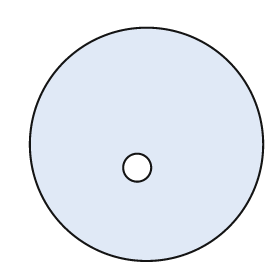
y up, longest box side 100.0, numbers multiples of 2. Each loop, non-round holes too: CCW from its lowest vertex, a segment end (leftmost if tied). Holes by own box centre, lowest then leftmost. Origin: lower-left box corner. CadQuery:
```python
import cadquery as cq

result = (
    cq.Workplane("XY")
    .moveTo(50.0, 50.0)
    .circle(50.0)
    .moveTo(46.0, 40.0)
    .circle(6.0)
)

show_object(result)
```